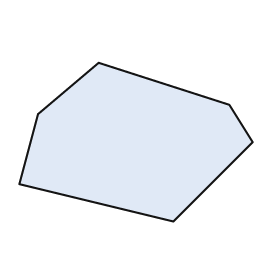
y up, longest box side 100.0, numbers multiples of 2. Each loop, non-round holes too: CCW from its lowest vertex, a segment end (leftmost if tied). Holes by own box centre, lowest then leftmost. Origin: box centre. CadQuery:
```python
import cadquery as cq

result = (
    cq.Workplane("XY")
    .moveTo(16.0, -34.0)
    .lineTo(50.0, 0.0)
    .lineTo(40.0, 16.0)
    .lineTo(-16.0, 34.0)
    .lineTo(-42.0, 12.0)
    .lineTo(-50.0, -18.0)
    .close()
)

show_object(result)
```